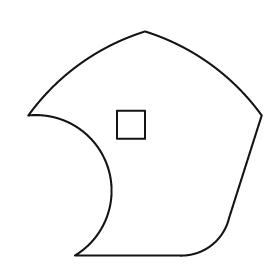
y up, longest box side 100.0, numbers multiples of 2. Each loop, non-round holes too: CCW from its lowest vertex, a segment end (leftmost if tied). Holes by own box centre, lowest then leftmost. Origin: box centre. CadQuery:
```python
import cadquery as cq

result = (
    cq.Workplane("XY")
    .moveTo(-30.0, -48.0)
    .lineTo(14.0, -48.0)
    .threePointArc((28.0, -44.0), (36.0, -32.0))
    .lineTo(50.0, 12.0)
    .threePointArc((28.0, 34.0), (0.0, 48.0))
    .threePointArc((-28.0, 34.0), (-50.0, 12.0))
    .threePointArc((-16.0, -10.0), (-30.0, -48.0))
    .close()
    .moveTo(-12.0, 2.0)
    .lineTo(0.0, 2.0)
    .lineTo(0.0, 14.0)
    .lineTo(-12.0, 14.0)
    .close()
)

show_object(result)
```